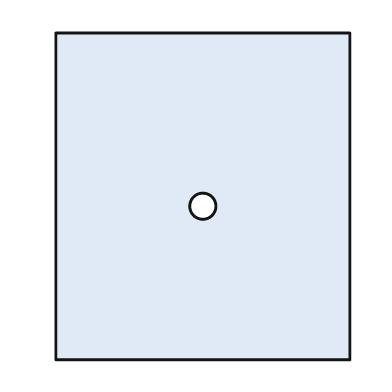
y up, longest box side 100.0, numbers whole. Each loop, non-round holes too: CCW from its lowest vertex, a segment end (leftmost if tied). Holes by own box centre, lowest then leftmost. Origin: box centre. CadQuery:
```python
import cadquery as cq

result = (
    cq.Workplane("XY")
    .moveTo(-45.0, -50.0)
    .lineTo(45.0, -50.0)
    .lineTo(45.0, 50.0)
    .lineTo(-45.0, 50.0)
    .close()
    .moveTo(0.0, -3.0)
    .circle(4.0)
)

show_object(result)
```